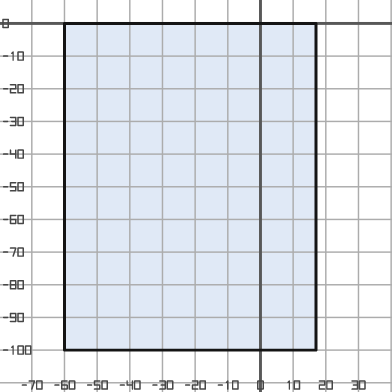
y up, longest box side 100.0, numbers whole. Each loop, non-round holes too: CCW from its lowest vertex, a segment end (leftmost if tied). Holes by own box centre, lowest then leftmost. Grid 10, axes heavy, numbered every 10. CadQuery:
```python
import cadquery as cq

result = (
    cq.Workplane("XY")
    .moveTo(-60.0, -100.0)
    .lineTo(17.0, -100.0)
    .lineTo(17.0, 0.0)
    .lineTo(-60.0, 0.0)
    .close()
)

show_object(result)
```